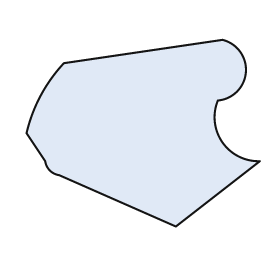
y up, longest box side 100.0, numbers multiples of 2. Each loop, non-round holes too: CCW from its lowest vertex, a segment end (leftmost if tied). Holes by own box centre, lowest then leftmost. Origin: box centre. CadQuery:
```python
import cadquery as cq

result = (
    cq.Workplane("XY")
    .moveTo(14.0, -40.0)
    .lineTo(50.0, -12.0)
    .threePointArc((34.0, -4.0), (32.0, 14.0))
    .threePointArc((44.0, 26.0), (34.0, 40.0))
    .lineTo(-34.0, 30.0)
    .threePointArc((-44.0, 16.0), (-50.0, 0.0))
    .lineTo(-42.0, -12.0)
    .threePointArc((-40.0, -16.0), (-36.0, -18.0))
    .close()
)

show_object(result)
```